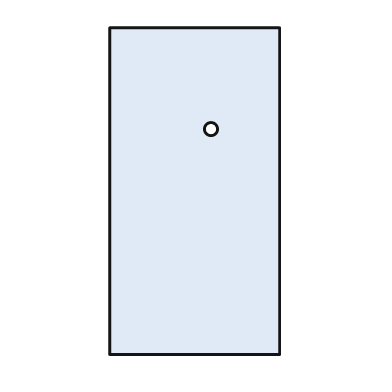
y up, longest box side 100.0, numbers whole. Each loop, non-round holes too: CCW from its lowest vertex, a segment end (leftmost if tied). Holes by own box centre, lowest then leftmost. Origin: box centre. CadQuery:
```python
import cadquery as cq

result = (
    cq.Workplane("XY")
    .moveTo(-26.0, -50.0)
    .lineTo(26.0, -50.0)
    .lineTo(26.0, 50.0)
    .lineTo(-26.0, 50.0)
    .close()
    .moveTo(5.0, 19.0)
    .circle(2.0)
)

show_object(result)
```